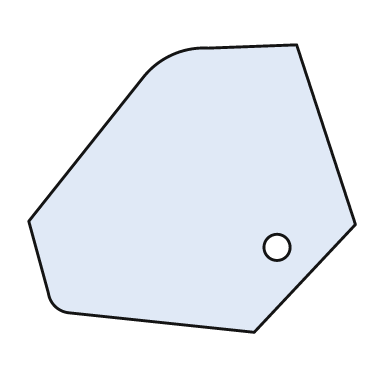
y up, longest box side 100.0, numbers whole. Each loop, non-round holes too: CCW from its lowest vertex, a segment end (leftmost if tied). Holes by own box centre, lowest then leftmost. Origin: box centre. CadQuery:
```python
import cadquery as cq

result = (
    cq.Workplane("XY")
    .moveTo(19.0, -44.0)
    .lineTo(50.0, -11.0)
    .lineTo(32.0, 44.0)
    .lineTo(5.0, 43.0)
    .threePointArc((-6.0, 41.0), (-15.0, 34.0))
    .lineTo(-50.0, -10.0)
    .lineTo(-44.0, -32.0)
    .threePointArc((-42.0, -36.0), (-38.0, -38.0))
    .close()
    .moveTo(26.0, -18.0)
    .circle(4.0)
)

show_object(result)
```